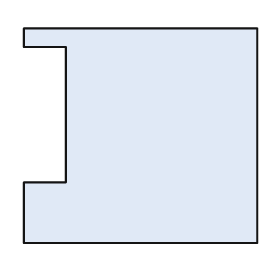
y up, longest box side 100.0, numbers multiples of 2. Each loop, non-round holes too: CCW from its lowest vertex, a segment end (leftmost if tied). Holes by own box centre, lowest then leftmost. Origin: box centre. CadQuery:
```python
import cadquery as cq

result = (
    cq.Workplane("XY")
    .moveTo(-50.0, -46.0)
    .lineTo(50.0, -46.0)
    .lineTo(50.0, 46.0)
    .lineTo(-50.0, 46.0)
    .lineTo(-50.0, 38.0)
    .lineTo(-32.0, 38.0)
    .lineTo(-32.0, -20.0)
    .lineTo(-50.0, -20.0)
    .close()
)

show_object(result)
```